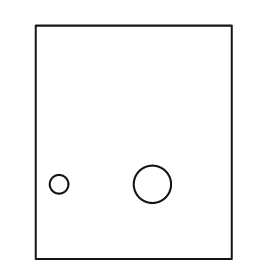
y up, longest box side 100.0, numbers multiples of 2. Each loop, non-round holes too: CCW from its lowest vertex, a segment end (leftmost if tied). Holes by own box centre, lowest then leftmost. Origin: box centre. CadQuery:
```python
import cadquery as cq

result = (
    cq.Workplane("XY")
    .moveTo(-42.0, -50.0)
    .lineTo(42.0, -50.0)
    .lineTo(42.0, 50.0)
    .lineTo(-42.0, 50.0)
    .close()
    .moveTo(-32.0, -18.0)
    .circle(4.0)
    .moveTo(8.0, -18.0)
    .circle(8.0)
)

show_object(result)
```